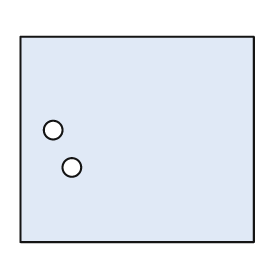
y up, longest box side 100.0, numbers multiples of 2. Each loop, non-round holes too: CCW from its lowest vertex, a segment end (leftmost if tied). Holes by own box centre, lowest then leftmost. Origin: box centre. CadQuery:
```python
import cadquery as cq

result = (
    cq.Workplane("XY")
    .moveTo(-50.0, -44.0)
    .lineTo(50.0, -44.0)
    .lineTo(50.0, 44.0)
    .lineTo(-50.0, 44.0)
    .close()
    .moveTo(-28.0, -12.0)
    .circle(4.0)
    .moveTo(-36.0, 4.0)
    .circle(4.0)
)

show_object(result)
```